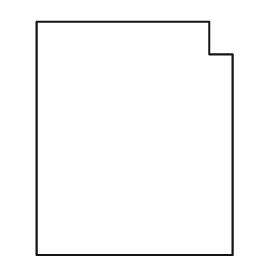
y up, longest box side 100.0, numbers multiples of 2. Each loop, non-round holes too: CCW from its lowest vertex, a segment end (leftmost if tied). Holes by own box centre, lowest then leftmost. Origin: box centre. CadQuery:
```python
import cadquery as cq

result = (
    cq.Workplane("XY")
    .moveTo(-42.0, -50.0)
    .lineTo(42.0, -50.0)
    .lineTo(42.0, 36.0)
    .lineTo(32.0, 36.0)
    .lineTo(32.0, 50.0)
    .lineTo(-42.0, 50.0)
    .close()
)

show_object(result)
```